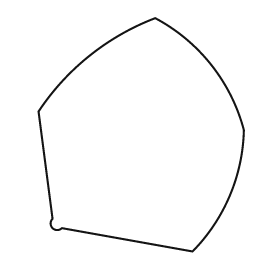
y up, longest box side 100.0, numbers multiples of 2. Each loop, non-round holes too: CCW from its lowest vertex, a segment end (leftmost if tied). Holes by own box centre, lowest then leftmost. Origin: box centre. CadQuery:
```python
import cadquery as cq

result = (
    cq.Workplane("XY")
    .moveTo(22.0, -50.0)
    .threePointArc((38.0, -26.0), (44.0, 2.0))
    .threePointArc((30.0, 30.0), (6.0, 50.0))
    .threePointArc((-22.0, 34.0), (-44.0, 10.0))
    .lineTo(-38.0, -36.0)
    .threePointArc((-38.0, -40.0), (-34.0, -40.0))
    .close()
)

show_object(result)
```